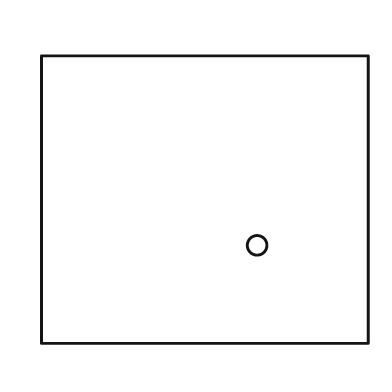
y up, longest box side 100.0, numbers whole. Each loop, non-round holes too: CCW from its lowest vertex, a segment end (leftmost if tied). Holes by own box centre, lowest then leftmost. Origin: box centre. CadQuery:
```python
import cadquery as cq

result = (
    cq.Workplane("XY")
    .moveTo(-50.0, -44.0)
    .lineTo(50.0, -44.0)
    .lineTo(50.0, 44.0)
    .lineTo(-50.0, 44.0)
    .close()
    .moveTo(16.0, -14.0)
    .circle(3.0)
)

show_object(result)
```